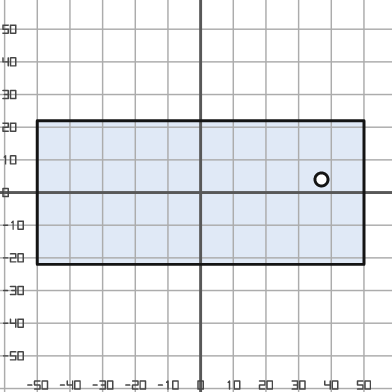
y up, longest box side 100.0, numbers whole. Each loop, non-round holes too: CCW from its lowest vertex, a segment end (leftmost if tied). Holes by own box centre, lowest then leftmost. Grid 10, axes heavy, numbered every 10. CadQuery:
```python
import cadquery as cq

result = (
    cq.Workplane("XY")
    .moveTo(-50.0, -22.0)
    .lineTo(50.0, -22.0)
    .lineTo(50.0, 22.0)
    .lineTo(-50.0, 22.0)
    .close()
    .moveTo(37.0, 4.0)
    .circle(2.0)
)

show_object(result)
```